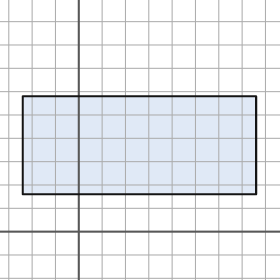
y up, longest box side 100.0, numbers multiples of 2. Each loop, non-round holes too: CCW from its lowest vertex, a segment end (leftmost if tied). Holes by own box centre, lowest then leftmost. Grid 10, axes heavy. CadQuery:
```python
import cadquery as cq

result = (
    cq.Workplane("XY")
    .moveTo(-24.0, 16.0)
    .lineTo(76.0, 16.0)
    .lineTo(76.0, 58.0)
    .lineTo(-24.0, 58.0)
    .close()
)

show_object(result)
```